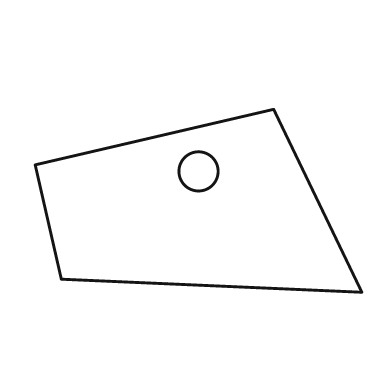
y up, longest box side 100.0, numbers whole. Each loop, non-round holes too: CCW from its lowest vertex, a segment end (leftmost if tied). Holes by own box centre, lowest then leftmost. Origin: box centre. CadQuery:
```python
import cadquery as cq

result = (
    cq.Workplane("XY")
    .moveTo(50.0, -28.0)
    .lineTo(23.0, 28.0)
    .lineTo(-50.0, 11.0)
    .lineTo(-42.0, -24.0)
    .close()
    .moveTo(0.0, 9.0)
    .circle(6.0)
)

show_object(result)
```